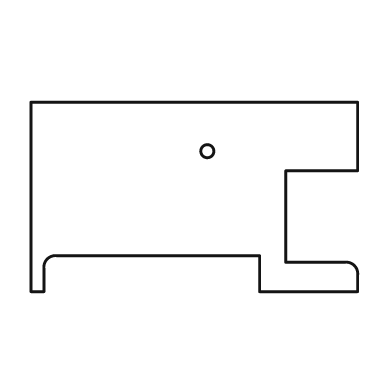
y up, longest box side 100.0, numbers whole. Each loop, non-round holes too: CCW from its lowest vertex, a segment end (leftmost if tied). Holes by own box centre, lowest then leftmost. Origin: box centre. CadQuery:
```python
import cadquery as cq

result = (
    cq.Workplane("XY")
    .moveTo(-50.0, -29.0)
    .lineTo(-46.0, -29.0)
    .lineTo(-46.0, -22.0)
    .threePointArc((-45.0, -19.0), (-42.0, -18.0))
    .lineTo(20.0, -18.0)
    .lineTo(20.0, -29.0)
    .lineTo(50.0, -29.0)
    .lineTo(50.0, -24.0)
    .threePointArc((49.0, -21.0), (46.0, -20.0))
    .lineTo(28.0, -20.0)
    .lineTo(28.0, 8.0)
    .lineTo(50.0, 8.0)
    .lineTo(50.0, 29.0)
    .lineTo(-50.0, 29.0)
    .close()
    .moveTo(4.0, 14.0)
    .circle(2.0)
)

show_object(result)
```